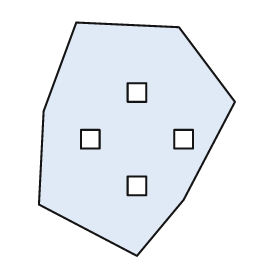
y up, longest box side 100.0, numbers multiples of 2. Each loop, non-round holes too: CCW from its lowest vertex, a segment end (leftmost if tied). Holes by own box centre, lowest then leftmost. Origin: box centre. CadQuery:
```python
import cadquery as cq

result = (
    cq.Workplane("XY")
    .moveTo(0.0, -50.0)
    .lineTo(20.0, -26.0)
    .lineTo(42.0, 16.0)
    .lineTo(18.0, 48.0)
    .lineTo(-26.0, 50.0)
    .lineTo(-40.0, 12.0)
    .lineTo(-42.0, -28.0)
    .close()
    .moveTo(-4.0, -24.0)
    .lineTo(4.0, -24.0)
    .lineTo(4.0, -16.0)
    .lineTo(-4.0, -16.0)
    .close()
    .moveTo(-24.0, -4.0)
    .lineTo(-16.0, -4.0)
    .lineTo(-16.0, 4.0)
    .lineTo(-24.0, 4.0)
    .close()
    .moveTo(16.0, -4.0)
    .lineTo(24.0, -4.0)
    .lineTo(24.0, 4.0)
    .lineTo(16.0, 4.0)
    .close()
    .moveTo(-4.0, 16.0)
    .lineTo(4.0, 16.0)
    .lineTo(4.0, 24.0)
    .lineTo(-4.0, 24.0)
    .close()
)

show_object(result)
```